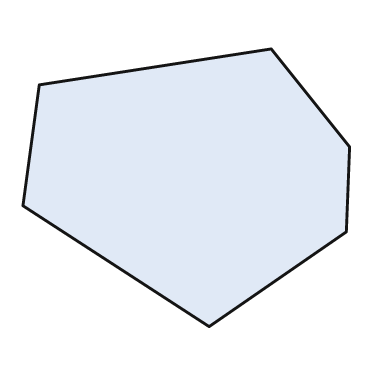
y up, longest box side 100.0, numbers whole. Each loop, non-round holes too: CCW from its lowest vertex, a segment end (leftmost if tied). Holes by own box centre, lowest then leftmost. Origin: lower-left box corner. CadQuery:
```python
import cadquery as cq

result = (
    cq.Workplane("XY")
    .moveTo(57.0, 0.0)
    .lineTo(99.0, 29.0)
    .lineTo(100.0, 55.0)
    .lineTo(76.0, 85.0)
    .lineTo(5.0, 74.0)
    .lineTo(0.0, 37.0)
    .close()
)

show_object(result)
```